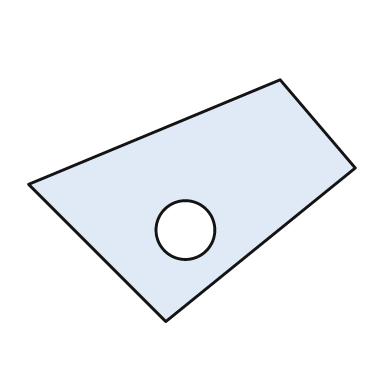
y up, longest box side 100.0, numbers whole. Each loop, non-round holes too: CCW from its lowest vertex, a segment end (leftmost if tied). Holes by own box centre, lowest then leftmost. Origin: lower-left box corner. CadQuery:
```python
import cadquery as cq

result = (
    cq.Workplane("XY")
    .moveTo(42.0, 0.0)
    .lineTo(100.0, 47.0)
    .lineTo(77.0, 74.0)
    .lineTo(0.0, 42.0)
    .close()
    .moveTo(48.0, 28.0)
    .circle(9.0)
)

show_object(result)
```